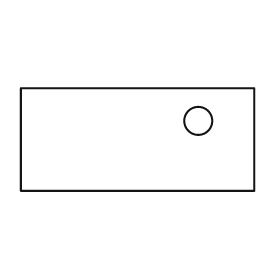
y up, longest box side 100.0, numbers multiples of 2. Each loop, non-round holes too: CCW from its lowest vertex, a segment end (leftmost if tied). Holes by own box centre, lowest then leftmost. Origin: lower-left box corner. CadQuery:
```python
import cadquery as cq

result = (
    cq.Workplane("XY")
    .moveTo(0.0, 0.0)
    .lineTo(100.0, 0.0)
    .lineTo(100.0, 44.0)
    .lineTo(0.0, 44.0)
    .close()
    .moveTo(76.0, 30.0)
    .circle(6.0)
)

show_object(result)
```